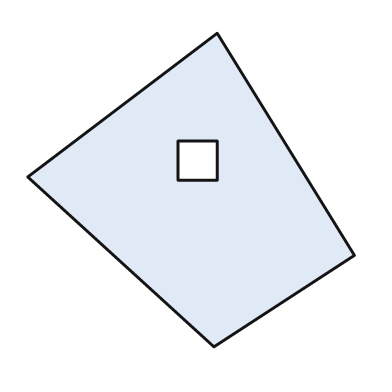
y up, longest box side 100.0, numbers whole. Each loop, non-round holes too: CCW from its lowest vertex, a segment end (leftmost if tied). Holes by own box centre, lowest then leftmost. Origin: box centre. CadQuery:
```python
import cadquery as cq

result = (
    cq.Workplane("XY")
    .moveTo(7.0, -48.0)
    .lineTo(50.0, -20.0)
    .lineTo(8.0, 48.0)
    .lineTo(-50.0, 4.0)
    .close()
    .moveTo(-4.0, 3.0)
    .lineTo(8.0, 3.0)
    .lineTo(8.0, 15.0)
    .lineTo(-4.0, 15.0)
    .close()
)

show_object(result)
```